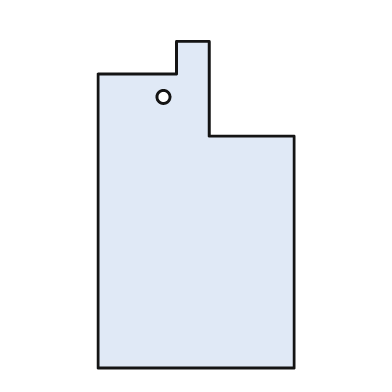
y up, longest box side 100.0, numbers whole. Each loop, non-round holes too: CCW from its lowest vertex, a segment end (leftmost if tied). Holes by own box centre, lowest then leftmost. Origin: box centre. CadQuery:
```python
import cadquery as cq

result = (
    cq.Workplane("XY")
    .moveTo(-30.0, -50.0)
    .lineTo(30.0, -50.0)
    .lineTo(30.0, 21.0)
    .lineTo(4.0, 21.0)
    .lineTo(4.0, 50.0)
    .lineTo(-6.0, 50.0)
    .lineTo(-6.0, 40.0)
    .lineTo(-30.0, 40.0)
    .close()
    .moveTo(-10.0, 33.0)
    .circle(2.0)
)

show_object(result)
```